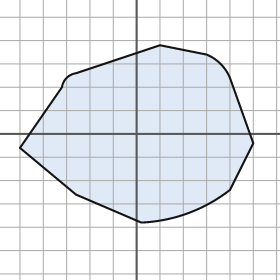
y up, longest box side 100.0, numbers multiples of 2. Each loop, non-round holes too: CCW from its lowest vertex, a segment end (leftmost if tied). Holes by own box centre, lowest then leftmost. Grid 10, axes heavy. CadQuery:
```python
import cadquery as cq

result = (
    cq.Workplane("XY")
    .moveTo(2.0, -38.0)
    .threePointArc((22.0, -34.0), (40.0, -24.0))
    .lineTo(50.0, -4.0)
    .lineTo(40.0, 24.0)
    .threePointArc((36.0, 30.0), (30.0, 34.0))
    .lineTo(10.0, 38.0)
    .lineTo(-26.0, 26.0)
    .threePointArc((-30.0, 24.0), (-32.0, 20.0))
    .lineTo(-50.0, -6.0)
    .lineTo(-26.0, -26.0)
    .close()
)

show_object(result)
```